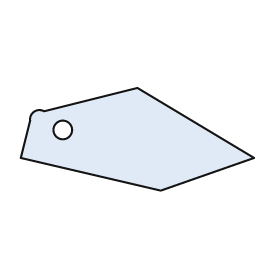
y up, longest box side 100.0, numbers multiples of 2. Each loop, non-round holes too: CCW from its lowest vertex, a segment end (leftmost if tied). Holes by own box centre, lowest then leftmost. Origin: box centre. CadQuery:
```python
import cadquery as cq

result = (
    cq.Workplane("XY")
    .moveTo(10.0, -22.0)
    .lineTo(50.0, -8.0)
    .lineTo(0.0, 22.0)
    .lineTo(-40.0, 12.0)
    .threePointArc((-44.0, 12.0), (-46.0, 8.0))
    .lineTo(-50.0, -8.0)
    .close()
    .moveTo(-32.0, 4.0)
    .circle(4.0)
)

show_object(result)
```